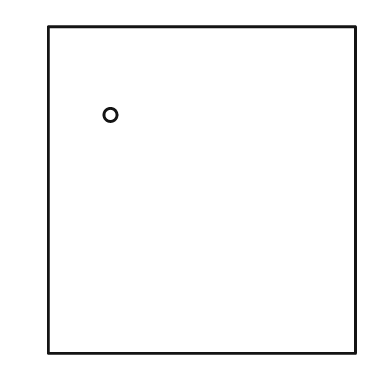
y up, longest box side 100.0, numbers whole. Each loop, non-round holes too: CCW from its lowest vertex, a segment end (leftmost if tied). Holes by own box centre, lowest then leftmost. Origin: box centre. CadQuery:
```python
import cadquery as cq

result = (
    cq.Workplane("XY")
    .moveTo(-47.0, -50.0)
    .lineTo(47.0, -50.0)
    .lineTo(47.0, 50.0)
    .lineTo(-47.0, 50.0)
    .close()
    .moveTo(-28.0, 23.0)
    .circle(2.0)
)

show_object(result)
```